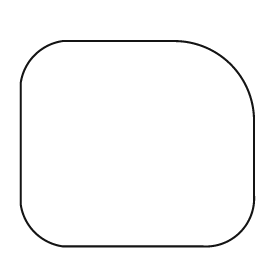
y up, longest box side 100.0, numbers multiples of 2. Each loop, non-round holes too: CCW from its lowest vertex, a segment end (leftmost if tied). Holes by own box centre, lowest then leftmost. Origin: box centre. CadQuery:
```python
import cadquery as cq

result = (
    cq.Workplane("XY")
    .moveTo(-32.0, -44.0)
    .lineTo(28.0, -44.0)
    .threePointArc((44.0, -38.0), (50.0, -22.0))
    .lineTo(50.0, 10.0)
    .threePointArc((40.0, 34.0), (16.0, 44.0))
    .lineTo(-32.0, 44.0)
    .threePointArc((-44.0, 38.0), (-50.0, 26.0))
    .lineTo(-50.0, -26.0)
    .threePointArc((-44.0, -38.0), (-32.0, -44.0))
    .close()
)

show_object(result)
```